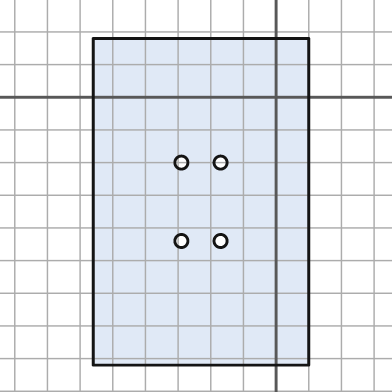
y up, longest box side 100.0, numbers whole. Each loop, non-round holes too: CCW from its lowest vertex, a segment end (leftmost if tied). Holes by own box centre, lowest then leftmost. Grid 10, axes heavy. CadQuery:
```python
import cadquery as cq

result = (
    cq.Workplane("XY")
    .moveTo(-56.0, -82.0)
    .lineTo(10.0, -82.0)
    .lineTo(10.0, 18.0)
    .lineTo(-56.0, 18.0)
    .close()
    .moveTo(-29.0, -44.0)
    .circle(2.0)
    .moveTo(-17.0, -44.0)
    .circle(2.0)
    .moveTo(-29.0, -20.0)
    .circle(2.0)
    .moveTo(-17.0, -20.0)
    .circle(2.0)
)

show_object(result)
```